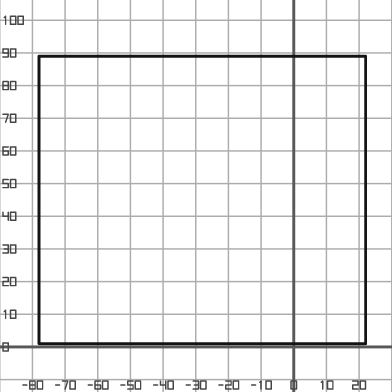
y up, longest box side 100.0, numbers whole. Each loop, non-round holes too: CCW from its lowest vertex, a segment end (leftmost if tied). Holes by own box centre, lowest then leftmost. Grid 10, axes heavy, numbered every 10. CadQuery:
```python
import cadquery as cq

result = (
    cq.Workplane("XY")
    .moveTo(-78.0, 1.0)
    .lineTo(22.0, 1.0)
    .lineTo(22.0, 89.0)
    .lineTo(-78.0, 89.0)
    .close()
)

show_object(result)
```